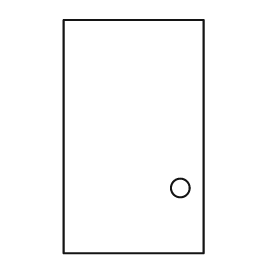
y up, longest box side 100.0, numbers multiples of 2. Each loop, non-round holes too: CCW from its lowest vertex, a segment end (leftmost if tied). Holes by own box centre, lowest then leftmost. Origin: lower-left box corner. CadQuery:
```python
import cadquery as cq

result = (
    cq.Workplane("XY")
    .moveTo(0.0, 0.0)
    .lineTo(60.0, 0.0)
    .lineTo(60.0, 100.0)
    .lineTo(0.0, 100.0)
    .close()
    .moveTo(50.0, 28.0)
    .circle(4.0)
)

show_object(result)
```